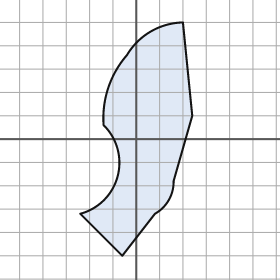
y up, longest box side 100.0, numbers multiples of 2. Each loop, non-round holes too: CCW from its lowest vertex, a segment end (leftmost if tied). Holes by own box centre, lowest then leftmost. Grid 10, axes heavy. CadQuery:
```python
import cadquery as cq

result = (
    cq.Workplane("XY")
    .moveTo(-6.0, -50.0)
    .lineTo(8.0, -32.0)
    .threePointArc((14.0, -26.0), (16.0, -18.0))
    .lineTo(24.0, 10.0)
    .lineTo(20.0, 50.0)
    .threePointArc((6.0, 46.0), (-4.0, 36.0))
    .threePointArc((-12.0, 22.0), (-14.0, 6.0))
    .threePointArc((-8.0, -16.0), (-24.0, -32.0))
    .close()
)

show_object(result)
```